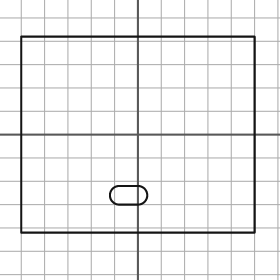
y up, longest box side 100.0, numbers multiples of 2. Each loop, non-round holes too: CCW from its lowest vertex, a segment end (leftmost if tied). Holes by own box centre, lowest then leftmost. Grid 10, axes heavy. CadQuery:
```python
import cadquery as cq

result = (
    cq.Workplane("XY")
    .moveTo(-50.0, -42.0)
    .lineTo(50.0, -42.0)
    .lineTo(50.0, 42.0)
    .lineTo(-50.0, 42.0)
    .close()
    .moveTo(-8.0, -30.0)
    .lineTo(0.0, -30.0)
    .threePointArc((4.0, -26.0), (0.0, -22.0))
    .lineTo(-8.0, -22.0)
    .threePointArc((-12.0, -26.0), (-8.0, -30.0))
    .close()
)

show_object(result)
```